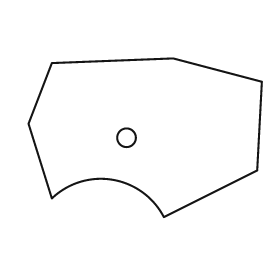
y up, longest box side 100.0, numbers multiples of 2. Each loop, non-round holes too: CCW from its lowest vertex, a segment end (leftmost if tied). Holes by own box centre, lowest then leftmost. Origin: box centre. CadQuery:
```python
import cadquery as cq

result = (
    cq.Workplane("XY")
    .moveTo(8.0, -34.0)
    .lineTo(48.0, -14.0)
    .lineTo(50.0, 24.0)
    .lineTo(12.0, 34.0)
    .lineTo(-40.0, 32.0)
    .lineTo(-50.0, 6.0)
    .lineTo(-40.0, -26.0)
    .threePointArc((-14.0, -18.0), (8.0, -34.0))
    .close()
    .moveTo(-8.0, 0.0)
    .circle(4.0)
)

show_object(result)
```